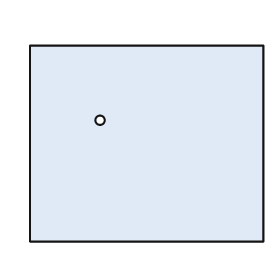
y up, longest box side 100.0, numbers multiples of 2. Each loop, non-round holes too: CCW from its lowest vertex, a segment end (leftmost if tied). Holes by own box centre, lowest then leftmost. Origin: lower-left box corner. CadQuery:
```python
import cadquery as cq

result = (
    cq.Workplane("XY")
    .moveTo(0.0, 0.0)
    .lineTo(100.0, 0.0)
    .lineTo(100.0, 84.0)
    .lineTo(0.0, 84.0)
    .close()
    .moveTo(30.0, 52.0)
    .circle(2.0)
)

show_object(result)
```